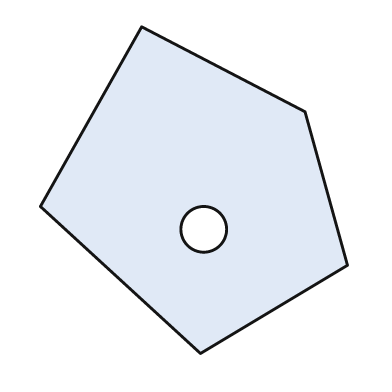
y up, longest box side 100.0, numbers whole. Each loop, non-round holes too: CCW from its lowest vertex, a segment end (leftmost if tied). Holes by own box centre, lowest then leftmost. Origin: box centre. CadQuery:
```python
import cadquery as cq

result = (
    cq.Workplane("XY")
    .moveTo(2.0, -50.0)
    .lineTo(47.0, -23.0)
    .lineTo(34.0, 24.0)
    .lineTo(-16.0, 50.0)
    .lineTo(-47.0, -5.0)
    .close()
    .moveTo(3.0, -12.0)
    .circle(7.0)
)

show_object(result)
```